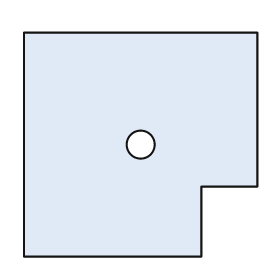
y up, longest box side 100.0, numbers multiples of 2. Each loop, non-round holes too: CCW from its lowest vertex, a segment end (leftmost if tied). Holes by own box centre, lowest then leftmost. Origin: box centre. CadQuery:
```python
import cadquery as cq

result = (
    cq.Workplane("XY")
    .moveTo(-50.0, -48.0)
    .lineTo(26.0, -48.0)
    .lineTo(26.0, -18.0)
    .lineTo(50.0, -18.0)
    .lineTo(50.0, 48.0)
    .lineTo(-50.0, 48.0)
    .close()
    .moveTo(0.0, 0.0)
    .circle(6.0)
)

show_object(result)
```